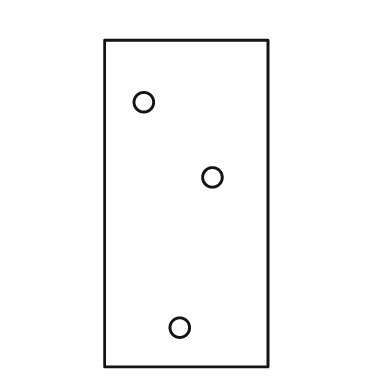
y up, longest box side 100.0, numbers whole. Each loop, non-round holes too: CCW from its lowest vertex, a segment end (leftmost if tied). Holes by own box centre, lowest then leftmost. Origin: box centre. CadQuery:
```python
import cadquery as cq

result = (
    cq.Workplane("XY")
    .moveTo(-25.0, -50.0)
    .lineTo(25.0, -50.0)
    .lineTo(25.0, 50.0)
    .lineTo(-25.0, 50.0)
    .close()
    .moveTo(-2.0, -38.0)
    .circle(3.0)
    .moveTo(8.0, 8.0)
    .circle(3.0)
    .moveTo(-13.0, 31.0)
    .circle(3.0)
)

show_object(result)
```